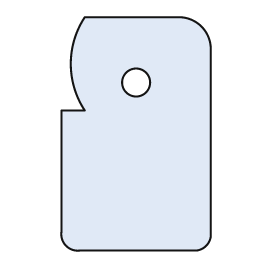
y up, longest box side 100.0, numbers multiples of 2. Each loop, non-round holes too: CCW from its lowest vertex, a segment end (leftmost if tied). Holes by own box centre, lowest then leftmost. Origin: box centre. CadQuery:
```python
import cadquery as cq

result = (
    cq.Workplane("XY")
    .moveTo(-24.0, -50.0)
    .lineTo(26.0, -50.0)
    .threePointArc((30.0, -48.0), (32.0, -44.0))
    .lineTo(32.0, 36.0)
    .threePointArc((28.0, 46.0), (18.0, 50.0))
    .lineTo(-22.0, 50.0)
    .threePointArc((-28.0, 30.0), (-22.0, 10.0))
    .lineTo(-32.0, 10.0)
    .lineTo(-32.0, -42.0)
    .threePointArc((-30.0, -48.0), (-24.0, -50.0))
    .close()
    .moveTo(0.0, 22.0)
    .circle(6.0)
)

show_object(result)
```